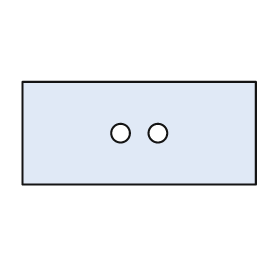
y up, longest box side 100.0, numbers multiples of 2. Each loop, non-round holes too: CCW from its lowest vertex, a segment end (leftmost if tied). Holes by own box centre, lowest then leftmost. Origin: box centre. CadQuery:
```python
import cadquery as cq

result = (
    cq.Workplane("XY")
    .moveTo(-50.0, -22.0)
    .lineTo(50.0, -22.0)
    .lineTo(50.0, 22.0)
    .lineTo(-50.0, 22.0)
    .close()
    .moveTo(-8.0, 0.0)
    .circle(4.0)
    .moveTo(8.0, 0.0)
    .circle(4.0)
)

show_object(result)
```